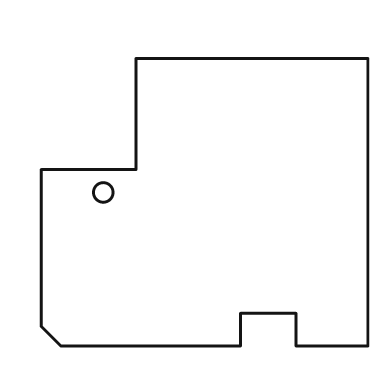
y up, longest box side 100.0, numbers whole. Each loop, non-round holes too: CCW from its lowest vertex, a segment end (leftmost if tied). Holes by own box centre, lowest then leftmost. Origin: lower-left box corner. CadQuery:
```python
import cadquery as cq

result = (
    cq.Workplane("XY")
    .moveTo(6.0, 0.0)
    .lineTo(61.0, 0.0)
    .lineTo(61.0, 10.0)
    .lineTo(78.0, 10.0)
    .lineTo(78.0, 0.0)
    .lineTo(100.0, 0.0)
    .lineTo(100.0, 88.0)
    .lineTo(29.0, 88.0)
    .lineTo(29.0, 54.0)
    .lineTo(0.0, 54.0)
    .lineTo(0.0, 6.0)
    .close()
    .moveTo(19.0, 47.0)
    .circle(3.0)
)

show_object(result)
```